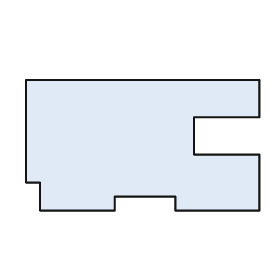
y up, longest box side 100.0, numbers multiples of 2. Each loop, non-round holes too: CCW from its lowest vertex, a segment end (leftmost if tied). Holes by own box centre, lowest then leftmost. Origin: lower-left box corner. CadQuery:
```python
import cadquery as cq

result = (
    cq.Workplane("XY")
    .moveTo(6.0, 0.0)
    .lineTo(38.0, 0.0)
    .lineTo(38.0, 6.0)
    .lineTo(64.0, 6.0)
    .lineTo(64.0, 0.0)
    .lineTo(100.0, 0.0)
    .lineTo(100.0, 24.0)
    .lineTo(72.0, 24.0)
    .lineTo(72.0, 40.0)
    .lineTo(100.0, 40.0)
    .lineTo(100.0, 56.0)
    .lineTo(0.0, 56.0)
    .lineTo(0.0, 12.0)
    .lineTo(6.0, 12.0)
    .close()
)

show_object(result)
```